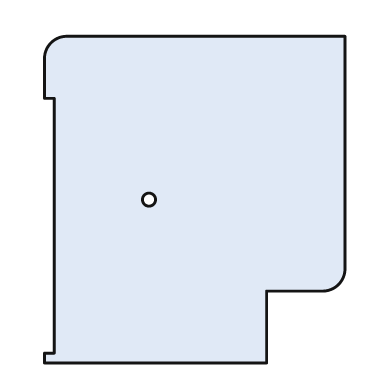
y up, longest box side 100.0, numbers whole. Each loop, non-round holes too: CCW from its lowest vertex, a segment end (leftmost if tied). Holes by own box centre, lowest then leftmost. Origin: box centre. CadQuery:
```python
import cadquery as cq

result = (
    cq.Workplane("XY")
    .moveTo(-46.0, -50.0)
    .lineTo(22.0, -50.0)
    .lineTo(22.0, -28.0)
    .lineTo(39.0, -28.0)
    .threePointArc((44.0, -26.0), (46.0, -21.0))
    .lineTo(46.0, 50.0)
    .lineTo(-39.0, 50.0)
    .threePointArc((-44.0, 48.0), (-46.0, 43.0))
    .lineTo(-46.0, 31.0)
    .lineTo(-43.0, 31.0)
    .lineTo(-43.0, -47.0)
    .lineTo(-46.0, -47.0)
    .close()
    .moveTo(-14.0, 0.0)
    .circle(2.0)
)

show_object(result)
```